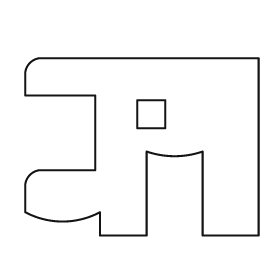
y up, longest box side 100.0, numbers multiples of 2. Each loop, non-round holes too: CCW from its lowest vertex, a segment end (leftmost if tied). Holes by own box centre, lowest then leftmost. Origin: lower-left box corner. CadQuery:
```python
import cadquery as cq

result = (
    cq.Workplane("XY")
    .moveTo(32.0, 0.0)
    .lineTo(52.0, 0.0)
    .lineTo(52.0, 36.0)
    .threePointArc((64.0, 34.0), (76.0, 36.0))
    .lineTo(76.0, 0.0)
    .lineTo(100.0, 0.0)
    .lineTo(100.0, 76.0)
    .lineTo(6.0, 76.0)
    .threePointArc((2.0, 74.0), (0.0, 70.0))
    .lineTo(0.0, 60.0)
    .lineTo(30.0, 60.0)
    .lineTo(30.0, 28.0)
    .lineTo(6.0, 28.0)
    .threePointArc((2.0, 26.0), (0.0, 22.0))
    .lineTo(0.0, 10.0)
    .threePointArc((16.0, 6.0), (32.0, 10.0))
    .close()
    .moveTo(48.0, 46.0)
    .lineTo(60.0, 46.0)
    .lineTo(60.0, 58.0)
    .lineTo(48.0, 58.0)
    .close()
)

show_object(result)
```